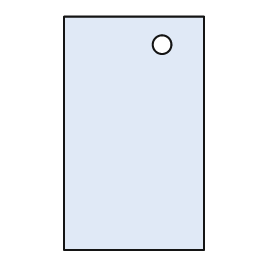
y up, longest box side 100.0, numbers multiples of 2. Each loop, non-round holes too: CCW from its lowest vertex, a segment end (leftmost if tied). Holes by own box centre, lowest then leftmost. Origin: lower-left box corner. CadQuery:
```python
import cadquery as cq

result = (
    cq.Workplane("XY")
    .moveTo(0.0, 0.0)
    .lineTo(60.0, 0.0)
    .lineTo(60.0, 100.0)
    .lineTo(0.0, 100.0)
    .close()
    .moveTo(42.0, 88.0)
    .circle(4.0)
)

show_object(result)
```